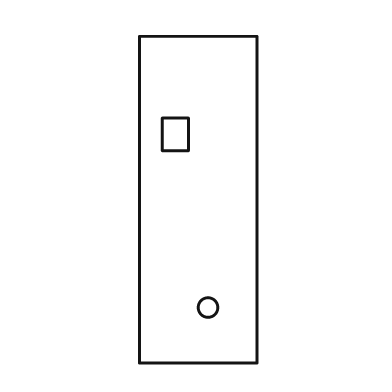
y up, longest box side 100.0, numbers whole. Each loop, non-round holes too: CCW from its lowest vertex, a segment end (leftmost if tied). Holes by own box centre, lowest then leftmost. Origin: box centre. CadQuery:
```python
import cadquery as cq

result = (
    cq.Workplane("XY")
    .moveTo(-18.0, -50.0)
    .lineTo(18.0, -50.0)
    .lineTo(18.0, 50.0)
    .lineTo(-18.0, 50.0)
    .close()
    .moveTo(3.0, -33.0)
    .circle(3.0)
    .moveTo(-11.0, 15.0)
    .lineTo(-3.0, 15.0)
    .lineTo(-3.0, 25.0)
    .lineTo(-11.0, 25.0)
    .close()
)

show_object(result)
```